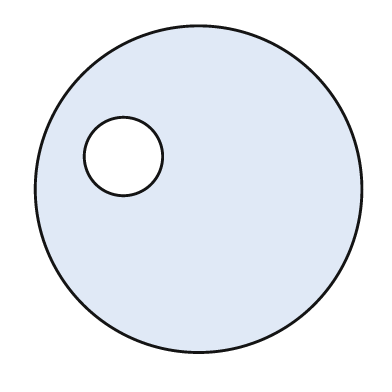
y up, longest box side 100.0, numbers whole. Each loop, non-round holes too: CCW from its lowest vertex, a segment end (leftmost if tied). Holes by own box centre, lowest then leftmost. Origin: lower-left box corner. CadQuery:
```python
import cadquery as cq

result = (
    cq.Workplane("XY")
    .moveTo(50.0, 50.0)
    .circle(50.0)
    .moveTo(27.0, 60.0)
    .circle(12.0)
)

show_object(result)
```